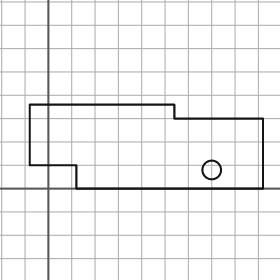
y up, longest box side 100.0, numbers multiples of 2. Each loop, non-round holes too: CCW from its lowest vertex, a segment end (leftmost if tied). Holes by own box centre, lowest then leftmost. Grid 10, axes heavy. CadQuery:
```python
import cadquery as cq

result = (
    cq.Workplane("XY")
    .moveTo(12.0, 0.0)
    .lineTo(92.0, 0.0)
    .lineTo(92.0, 30.0)
    .lineTo(54.0, 30.0)
    .lineTo(54.0, 36.0)
    .lineTo(-8.0, 36.0)
    .lineTo(-8.0, 10.0)
    .lineTo(12.0, 10.0)
    .close()
    .moveTo(70.0, 8.0)
    .circle(4.0)
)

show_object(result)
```